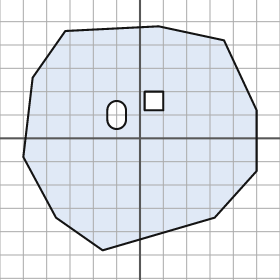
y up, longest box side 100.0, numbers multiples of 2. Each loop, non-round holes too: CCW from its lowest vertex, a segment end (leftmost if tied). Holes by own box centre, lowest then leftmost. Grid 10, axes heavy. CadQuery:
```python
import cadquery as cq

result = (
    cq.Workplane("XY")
    .moveTo(-16.0, -48.0)
    .lineTo(32.0, -34.0)
    .lineTo(50.0, -14.0)
    .lineTo(50.0, 12.0)
    .lineTo(36.0, 42.0)
    .lineTo(8.0, 48.0)
    .lineTo(-32.0, 46.0)
    .lineTo(-46.0, 26.0)
    .lineTo(-50.0, -8.0)
    .lineTo(-36.0, -34.0)
    .close()
    .moveTo(-14.0, 8.0)
    .threePointArc((-10.0, 4.0), (-6.0, 8.0))
    .lineTo(-6.0, 12.0)
    .threePointArc((-10.0, 16.0), (-14.0, 12.0))
    .close()
    .moveTo(2.0, 12.0)
    .lineTo(10.0, 12.0)
    .lineTo(10.0, 20.0)
    .lineTo(2.0, 20.0)
    .close()
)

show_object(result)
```